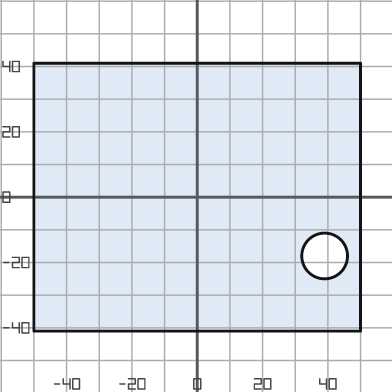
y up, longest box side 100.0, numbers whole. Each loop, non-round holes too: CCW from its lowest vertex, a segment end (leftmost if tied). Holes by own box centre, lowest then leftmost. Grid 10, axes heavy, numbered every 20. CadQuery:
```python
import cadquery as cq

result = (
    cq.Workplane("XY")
    .moveTo(-50.0, -41.0)
    .lineTo(50.0, -41.0)
    .lineTo(50.0, 41.0)
    .lineTo(-50.0, 41.0)
    .close()
    .moveTo(39.0, -18.0)
    .circle(7.0)
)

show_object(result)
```